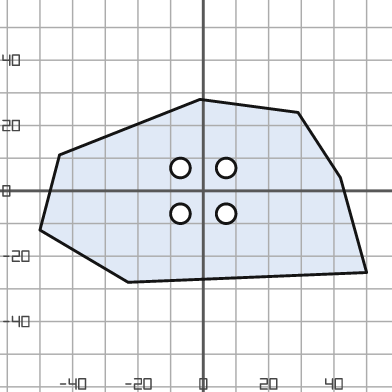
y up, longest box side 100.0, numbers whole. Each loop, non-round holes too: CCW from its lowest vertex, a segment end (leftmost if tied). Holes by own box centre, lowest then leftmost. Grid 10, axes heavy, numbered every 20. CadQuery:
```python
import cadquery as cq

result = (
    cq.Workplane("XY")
    .moveTo(-23.0, -28.0)
    .lineTo(50.0, -25.0)
    .lineTo(42.0, 4.0)
    .lineTo(29.0, 24.0)
    .lineTo(-1.0, 28.0)
    .lineTo(-44.0, 11.0)
    .lineTo(-50.0, -12.0)
    .close()
    .moveTo(-7.0, -7.0)
    .circle(3.0)
    .moveTo(7.0, -7.0)
    .circle(3.0)
    .moveTo(-7.0, 7.0)
    .circle(3.0)
    .moveTo(7.0, 7.0)
    .circle(3.0)
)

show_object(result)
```